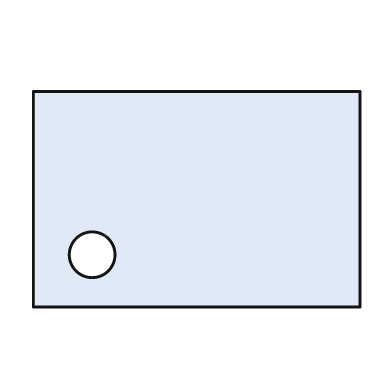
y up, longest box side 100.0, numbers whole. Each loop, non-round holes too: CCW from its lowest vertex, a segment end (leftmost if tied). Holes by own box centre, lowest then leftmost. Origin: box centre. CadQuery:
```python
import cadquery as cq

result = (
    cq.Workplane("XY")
    .moveTo(-50.0, -33.0)
    .lineTo(50.0, -33.0)
    .lineTo(50.0, 33.0)
    .lineTo(-50.0, 33.0)
    .close()
    .moveTo(-32.0, -17.0)
    .circle(7.0)
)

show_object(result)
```